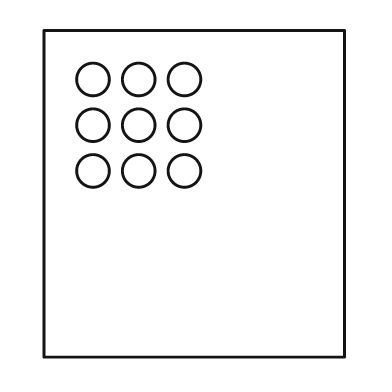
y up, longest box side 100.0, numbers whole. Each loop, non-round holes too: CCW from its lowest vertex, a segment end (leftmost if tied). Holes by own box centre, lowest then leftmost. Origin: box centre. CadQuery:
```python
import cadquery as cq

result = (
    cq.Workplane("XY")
    .moveTo(-46.0, -50.0)
    .lineTo(46.0, -50.0)
    .lineTo(46.0, 50.0)
    .lineTo(-46.0, 50.0)
    .close()
    .moveTo(-31.0, 7.0)
    .circle(5.0)
    .moveTo(-17.0, 7.0)
    .circle(5.0)
    .moveTo(-3.0, 7.0)
    .circle(5.0)
    .moveTo(-31.0, 21.0)
    .circle(5.0)
    .moveTo(-17.0, 21.0)
    .circle(5.0)
    .moveTo(-3.0, 21.0)
    .circle(5.0)
    .moveTo(-31.0, 35.0)
    .circle(5.0)
    .moveTo(-17.0, 35.0)
    .circle(5.0)
    .moveTo(-3.0, 35.0)
    .circle(5.0)
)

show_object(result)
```